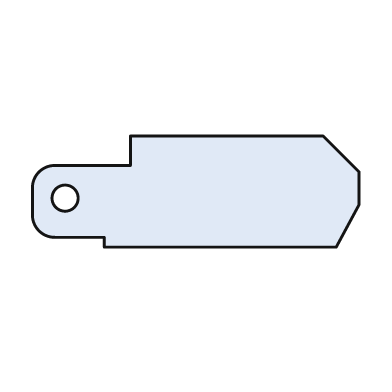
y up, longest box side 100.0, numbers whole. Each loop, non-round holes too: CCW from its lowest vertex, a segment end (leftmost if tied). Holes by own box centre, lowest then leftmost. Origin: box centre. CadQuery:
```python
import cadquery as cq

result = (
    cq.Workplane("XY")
    .moveTo(-28.0, -17.0)
    .lineTo(43.0, -17.0)
    .lineTo(50.0, -4.0)
    .lineTo(50.0, 6.0)
    .lineTo(39.0, 17.0)
    .lineTo(-20.0, 17.0)
    .lineTo(-20.0, 8.0)
    .lineTo(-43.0, 8.0)
    .threePointArc((-48.0, 6.0), (-50.0, 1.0))
    .lineTo(-50.0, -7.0)
    .threePointArc((-48.0, -12.0), (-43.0, -14.0))
    .lineTo(-28.0, -14.0)
    .close()
    .moveTo(-40.0, -2.0)
    .circle(4.0)
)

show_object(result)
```